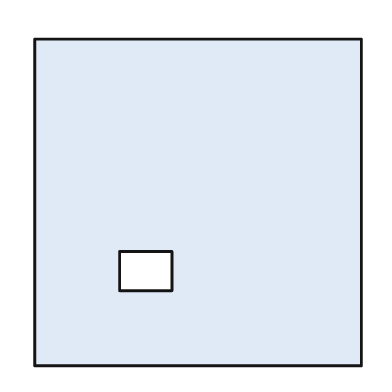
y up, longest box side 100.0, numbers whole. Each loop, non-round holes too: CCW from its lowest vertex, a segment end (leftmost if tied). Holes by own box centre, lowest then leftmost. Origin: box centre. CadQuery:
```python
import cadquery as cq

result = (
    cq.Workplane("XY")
    .moveTo(-50.0, -50.0)
    .lineTo(50.0, -50.0)
    .lineTo(50.0, 50.0)
    .lineTo(-50.0, 50.0)
    .close()
    .moveTo(-24.0, -27.0)
    .lineTo(-8.0, -27.0)
    .lineTo(-8.0, -15.0)
    .lineTo(-24.0, -15.0)
    .close()
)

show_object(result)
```